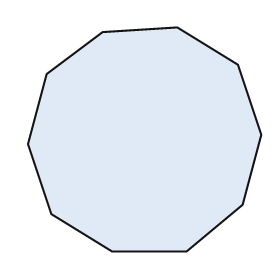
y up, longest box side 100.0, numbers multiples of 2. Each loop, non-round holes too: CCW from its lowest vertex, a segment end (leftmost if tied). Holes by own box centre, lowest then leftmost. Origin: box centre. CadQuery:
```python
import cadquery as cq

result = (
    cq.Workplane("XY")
    .moveTo(-14.0, -48.0)
    .lineTo(18.0, -48.0)
    .lineTo(42.0, -28.0)
    .lineTo(50.0, 2.0)
    .lineTo(40.0, 32.0)
    .lineTo(14.0, 48.0)
    .lineTo(-18.0, 46.0)
    .lineTo(-42.0, 28.0)
    .lineTo(-50.0, -2.0)
    .lineTo(-40.0, -32.0)
    .close()
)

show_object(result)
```